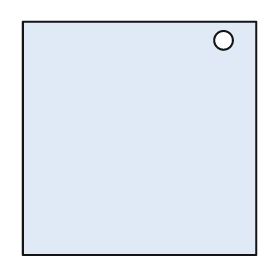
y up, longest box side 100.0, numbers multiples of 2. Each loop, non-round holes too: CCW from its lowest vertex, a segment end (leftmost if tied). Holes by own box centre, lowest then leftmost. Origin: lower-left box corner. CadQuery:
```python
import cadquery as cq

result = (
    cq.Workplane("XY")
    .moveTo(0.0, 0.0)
    .lineTo(100.0, 0.0)
    .lineTo(100.0, 100.0)
    .lineTo(0.0, 100.0)
    .close()
    .moveTo(86.0, 92.0)
    .circle(4.0)
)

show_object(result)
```